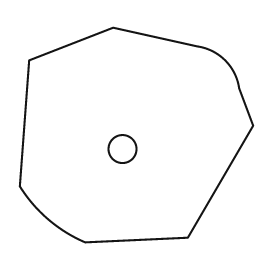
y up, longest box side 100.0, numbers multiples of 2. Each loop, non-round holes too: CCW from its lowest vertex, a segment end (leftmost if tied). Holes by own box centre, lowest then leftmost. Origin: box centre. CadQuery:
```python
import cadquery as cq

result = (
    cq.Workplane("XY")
    .moveTo(-22.0, -46.0)
    .lineTo(22.0, -44.0)
    .lineTo(50.0, 4.0)
    .lineTo(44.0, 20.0)
    .threePointArc((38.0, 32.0), (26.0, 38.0))
    .lineTo(-10.0, 46.0)
    .lineTo(-46.0, 32.0)
    .lineTo(-50.0, -22.0)
    .threePointArc((-38.0, -36.0), (-22.0, -46.0))
    .close()
    .moveTo(-6.0, -6.0)
    .circle(6.0)
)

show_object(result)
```